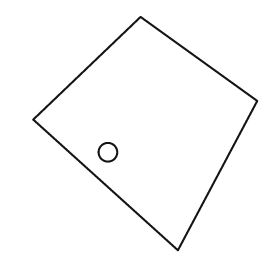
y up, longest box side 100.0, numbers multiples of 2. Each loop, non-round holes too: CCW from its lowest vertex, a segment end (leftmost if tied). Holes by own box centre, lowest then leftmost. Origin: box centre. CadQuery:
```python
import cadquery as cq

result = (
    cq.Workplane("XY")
    .moveTo(14.0, -50.0)
    .lineTo(48.0, 14.0)
    .lineTo(-2.0, 50.0)
    .lineTo(-48.0, 6.0)
    .close()
    .moveTo(-16.0, -8.0)
    .circle(4.0)
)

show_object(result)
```